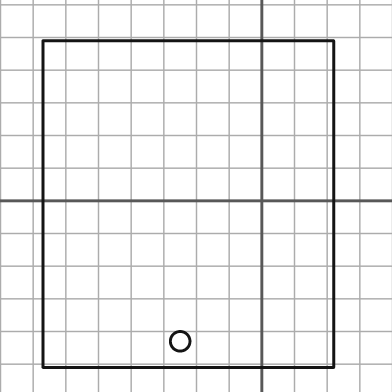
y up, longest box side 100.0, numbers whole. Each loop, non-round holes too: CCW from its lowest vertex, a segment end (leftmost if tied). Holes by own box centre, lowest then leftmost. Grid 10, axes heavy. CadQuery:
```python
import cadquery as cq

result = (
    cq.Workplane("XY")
    .moveTo(-67.0, -51.0)
    .lineTo(22.0, -51.0)
    .lineTo(22.0, 49.0)
    .lineTo(-67.0, 49.0)
    .close()
    .moveTo(-25.0, -43.0)
    .circle(3.0)
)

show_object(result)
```